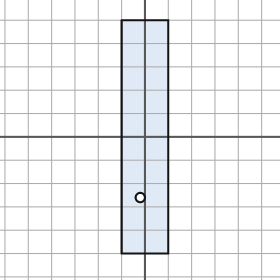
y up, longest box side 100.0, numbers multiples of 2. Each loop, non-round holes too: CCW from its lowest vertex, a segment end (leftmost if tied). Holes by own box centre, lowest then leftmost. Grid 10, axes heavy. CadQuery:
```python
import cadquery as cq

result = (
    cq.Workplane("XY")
    .moveTo(-10.0, -50.0)
    .lineTo(10.0, -50.0)
    .lineTo(10.0, 50.0)
    .lineTo(-10.0, 50.0)
    .close()
    .moveTo(-2.0, -26.0)
    .circle(2.0)
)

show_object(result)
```